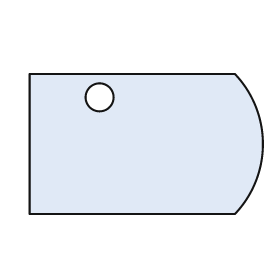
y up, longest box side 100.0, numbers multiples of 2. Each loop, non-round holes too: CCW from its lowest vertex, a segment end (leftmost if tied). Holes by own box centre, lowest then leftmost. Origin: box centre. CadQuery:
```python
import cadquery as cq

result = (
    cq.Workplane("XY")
    .moveTo(-50.0, -30.0)
    .lineTo(38.0, -30.0)
    .threePointArc((50.0, 0.0), (38.0, 30.0))
    .lineTo(-50.0, 30.0)
    .close()
    .moveTo(-20.0, 20.0)
    .circle(6.0)
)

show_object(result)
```